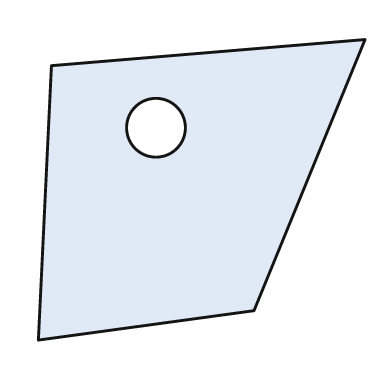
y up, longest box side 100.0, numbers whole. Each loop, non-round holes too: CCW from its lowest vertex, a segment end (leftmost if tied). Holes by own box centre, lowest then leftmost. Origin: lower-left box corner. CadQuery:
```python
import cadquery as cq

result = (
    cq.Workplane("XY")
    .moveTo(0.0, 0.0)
    .lineTo(66.0, 9.0)
    .lineTo(100.0, 92.0)
    .lineTo(4.0, 84.0)
    .close()
    .moveTo(36.0, 65.0)
    .circle(9.0)
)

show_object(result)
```